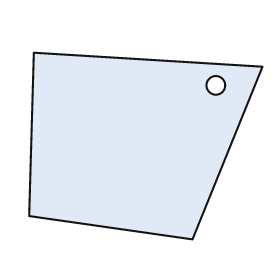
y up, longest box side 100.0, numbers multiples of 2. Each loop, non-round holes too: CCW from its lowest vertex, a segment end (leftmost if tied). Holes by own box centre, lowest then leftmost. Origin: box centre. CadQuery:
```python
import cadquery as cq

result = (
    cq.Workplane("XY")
    .moveTo(20.0, -40.0)
    .lineTo(50.0, 34.0)
    .lineTo(-48.0, 40.0)
    .lineTo(-50.0, -30.0)
    .close()
    .moveTo(30.0, 26.0)
    .circle(4.0)
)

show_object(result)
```